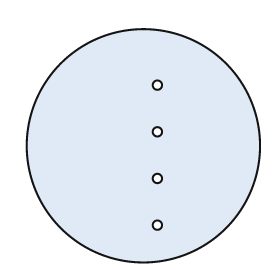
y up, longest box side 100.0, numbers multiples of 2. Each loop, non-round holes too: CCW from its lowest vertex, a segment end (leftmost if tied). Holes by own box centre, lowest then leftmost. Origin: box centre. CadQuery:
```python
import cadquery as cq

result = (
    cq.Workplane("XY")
    .moveTo(0.0, 0.0)
    .circle(50.0)
    .moveTo(6.0, -34.0)
    .circle(2.0)
    .moveTo(6.0, -14.0)
    .circle(2.0)
    .moveTo(6.0, 6.0)
    .circle(2.0)
    .moveTo(6.0, 26.0)
    .circle(2.0)
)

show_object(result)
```